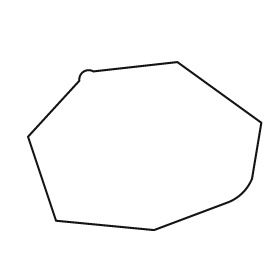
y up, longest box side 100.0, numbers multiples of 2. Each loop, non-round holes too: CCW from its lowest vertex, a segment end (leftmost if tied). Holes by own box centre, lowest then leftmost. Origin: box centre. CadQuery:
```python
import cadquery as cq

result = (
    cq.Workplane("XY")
    .moveTo(4.0, -36.0)
    .lineTo(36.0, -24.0)
    .threePointArc((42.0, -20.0), (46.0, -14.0))
    .lineTo(50.0, 10.0)
    .lineTo(14.0, 36.0)
    .lineTo(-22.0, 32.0)
    .threePointArc((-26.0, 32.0), (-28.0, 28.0))
    .lineTo(-50.0, 4.0)
    .lineTo(-38.0, -32.0)
    .close()
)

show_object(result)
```